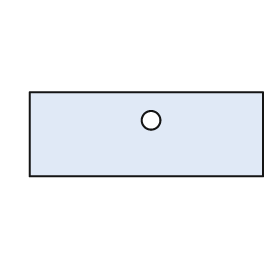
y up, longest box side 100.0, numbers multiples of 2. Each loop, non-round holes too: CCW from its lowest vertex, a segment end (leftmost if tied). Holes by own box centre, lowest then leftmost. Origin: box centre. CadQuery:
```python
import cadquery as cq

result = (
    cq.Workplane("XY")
    .moveTo(-50.0, -18.0)
    .lineTo(50.0, -18.0)
    .lineTo(50.0, 18.0)
    .lineTo(-50.0, 18.0)
    .close()
    .moveTo(2.0, 6.0)
    .circle(4.0)
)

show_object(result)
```